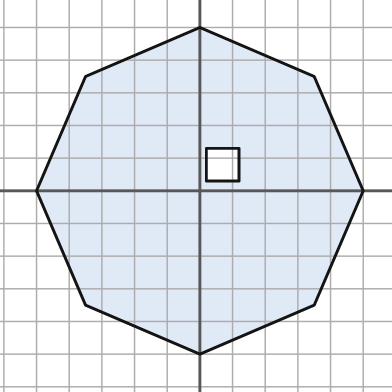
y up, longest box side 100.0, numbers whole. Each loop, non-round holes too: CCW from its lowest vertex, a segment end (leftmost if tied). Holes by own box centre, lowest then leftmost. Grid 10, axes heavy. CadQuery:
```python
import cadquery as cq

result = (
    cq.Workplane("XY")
    .moveTo(0.0, -50.0)
    .lineTo(35.0, -35.0)
    .lineTo(50.0, 0.0)
    .lineTo(35.0, 35.0)
    .lineTo(0.0, 50.0)
    .lineTo(-35.0, 35.0)
    .lineTo(-50.0, 0.0)
    .lineTo(-35.0, -35.0)
    .close()
    .moveTo(2.0, 3.0)
    .lineTo(12.0, 3.0)
    .lineTo(12.0, 13.0)
    .lineTo(2.0, 13.0)
    .close()
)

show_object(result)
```